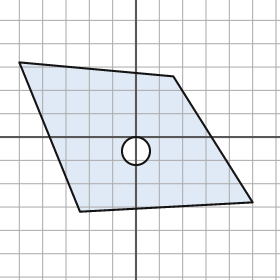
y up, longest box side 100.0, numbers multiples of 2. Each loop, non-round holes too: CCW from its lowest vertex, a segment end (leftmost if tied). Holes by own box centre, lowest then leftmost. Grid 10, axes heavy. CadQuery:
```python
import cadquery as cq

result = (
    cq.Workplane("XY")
    .moveTo(-24.0, -32.0)
    .lineTo(50.0, -28.0)
    .lineTo(16.0, 26.0)
    .lineTo(-50.0, 32.0)
    .close()
    .moveTo(0.0, -6.0)
    .circle(6.0)
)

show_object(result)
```